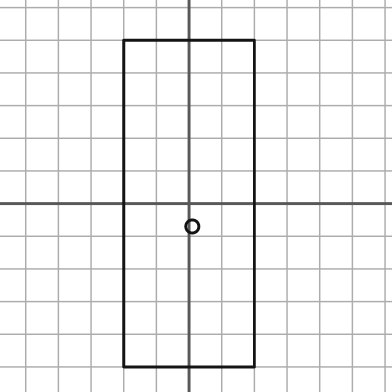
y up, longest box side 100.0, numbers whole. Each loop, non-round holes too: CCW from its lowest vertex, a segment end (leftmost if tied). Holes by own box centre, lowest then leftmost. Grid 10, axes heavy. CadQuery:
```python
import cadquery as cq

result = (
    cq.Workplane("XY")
    .moveTo(-20.0, -50.0)
    .lineTo(20.0, -50.0)
    .lineTo(20.0, 50.0)
    .lineTo(-20.0, 50.0)
    .close()
    .moveTo(1.0, -7.0)
    .circle(2.0)
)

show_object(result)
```